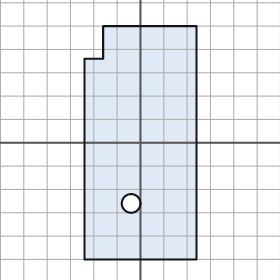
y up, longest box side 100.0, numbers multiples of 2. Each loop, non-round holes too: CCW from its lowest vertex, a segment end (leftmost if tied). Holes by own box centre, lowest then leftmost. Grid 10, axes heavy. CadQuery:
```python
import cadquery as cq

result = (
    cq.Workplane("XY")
    .moveTo(-24.0, -50.0)
    .lineTo(24.0, -50.0)
    .lineTo(24.0, 50.0)
    .lineTo(-16.0, 50.0)
    .lineTo(-16.0, 36.0)
    .lineTo(-24.0, 36.0)
    .close()
    .moveTo(-4.0, -26.0)
    .circle(4.0)
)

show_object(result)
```